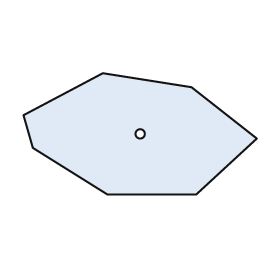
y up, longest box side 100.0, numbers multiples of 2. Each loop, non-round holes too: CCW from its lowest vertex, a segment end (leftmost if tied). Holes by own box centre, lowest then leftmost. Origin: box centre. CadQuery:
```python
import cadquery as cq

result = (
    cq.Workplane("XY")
    .moveTo(-14.0, -26.0)
    .lineTo(24.0, -26.0)
    .lineTo(50.0, -2.0)
    .lineTo(22.0, 20.0)
    .lineTo(-16.0, 26.0)
    .lineTo(-50.0, 8.0)
    .lineTo(-46.0, -6.0)
    .close()
    .moveTo(0.0, 0.0)
    .circle(2.0)
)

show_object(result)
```